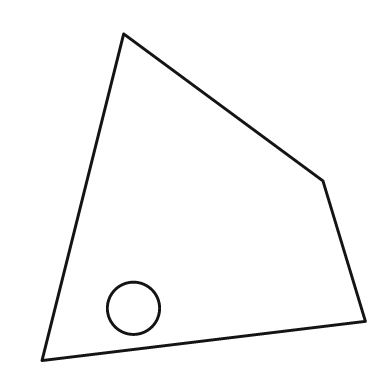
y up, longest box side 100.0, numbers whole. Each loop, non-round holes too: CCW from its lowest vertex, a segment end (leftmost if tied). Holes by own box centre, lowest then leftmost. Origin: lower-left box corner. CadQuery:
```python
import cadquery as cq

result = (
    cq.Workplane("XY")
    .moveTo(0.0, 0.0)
    .lineTo(99.0, 12.0)
    .lineTo(86.0, 55.0)
    .lineTo(25.0, 100.0)
    .close()
    .moveTo(28.0, 16.0)
    .circle(8.0)
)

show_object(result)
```